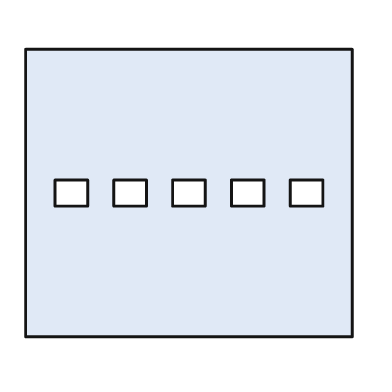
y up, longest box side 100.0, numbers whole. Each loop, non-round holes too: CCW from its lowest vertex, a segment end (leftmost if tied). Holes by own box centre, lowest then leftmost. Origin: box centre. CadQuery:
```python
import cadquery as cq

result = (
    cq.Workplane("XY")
    .moveTo(-50.0, -44.0)
    .lineTo(50.0, -44.0)
    .lineTo(50.0, 44.0)
    .lineTo(-50.0, 44.0)
    .close()
    .moveTo(-41.0, -4.0)
    .lineTo(-31.0, -4.0)
    .lineTo(-31.0, 4.0)
    .lineTo(-41.0, 4.0)
    .close()
    .moveTo(-23.0, -4.0)
    .lineTo(-13.0, -4.0)
    .lineTo(-13.0, 4.0)
    .lineTo(-23.0, 4.0)
    .close()
    .moveTo(-5.0, -4.0)
    .lineTo(5.0, -4.0)
    .lineTo(5.0, 4.0)
    .lineTo(-5.0, 4.0)
    .close()
    .moveTo(13.0, -4.0)
    .lineTo(23.0, -4.0)
    .lineTo(23.0, 4.0)
    .lineTo(13.0, 4.0)
    .close()
    .moveTo(31.0, -4.0)
    .lineTo(41.0, -4.0)
    .lineTo(41.0, 4.0)
    .lineTo(31.0, 4.0)
    .close()
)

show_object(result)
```